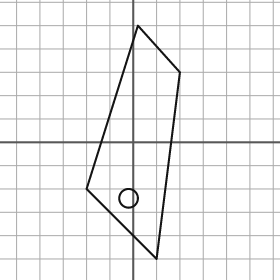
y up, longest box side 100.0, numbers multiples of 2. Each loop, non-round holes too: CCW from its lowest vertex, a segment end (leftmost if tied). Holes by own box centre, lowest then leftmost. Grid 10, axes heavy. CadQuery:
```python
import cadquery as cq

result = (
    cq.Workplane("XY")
    .moveTo(10.0, -50.0)
    .lineTo(20.0, 30.0)
    .lineTo(2.0, 50.0)
    .lineTo(-20.0, -20.0)
    .close()
    .moveTo(-2.0, -24.0)
    .circle(4.0)
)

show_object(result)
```